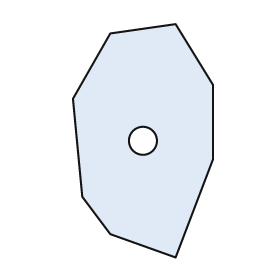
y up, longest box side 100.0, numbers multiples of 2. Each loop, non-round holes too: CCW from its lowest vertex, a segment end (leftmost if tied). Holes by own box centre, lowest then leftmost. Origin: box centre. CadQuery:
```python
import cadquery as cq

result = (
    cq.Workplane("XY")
    .moveTo(14.0, -50.0)
    .lineTo(30.0, -8.0)
    .lineTo(30.0, 24.0)
    .lineTo(14.0, 50.0)
    .lineTo(-14.0, 46.0)
    .lineTo(-30.0, 18.0)
    .lineTo(-26.0, -24.0)
    .lineTo(-14.0, -40.0)
    .close()
    .moveTo(0.0, 0.0)
    .circle(6.0)
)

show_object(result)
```